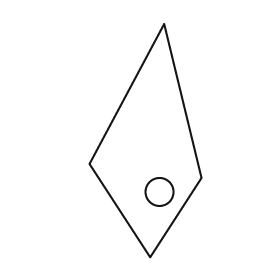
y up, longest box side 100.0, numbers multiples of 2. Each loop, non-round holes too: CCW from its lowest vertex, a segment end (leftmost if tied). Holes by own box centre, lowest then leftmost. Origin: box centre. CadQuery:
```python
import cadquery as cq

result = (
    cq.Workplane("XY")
    .moveTo(2.0, -50.0)
    .lineTo(24.0, -16.0)
    .lineTo(8.0, 50.0)
    .lineTo(-24.0, -10.0)
    .close()
    .moveTo(6.0, -22.0)
    .circle(6.0)
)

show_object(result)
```